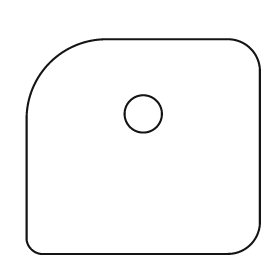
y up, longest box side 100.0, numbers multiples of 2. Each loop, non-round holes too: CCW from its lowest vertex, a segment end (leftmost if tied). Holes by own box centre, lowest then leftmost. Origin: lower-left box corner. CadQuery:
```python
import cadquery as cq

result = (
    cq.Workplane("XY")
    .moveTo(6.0, 0.0)
    .lineTo(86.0, 0.0)
    .threePointArc((96.0, 4.0), (100.0, 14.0))
    .lineTo(100.0, 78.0)
    .threePointArc((96.0, 88.0), (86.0, 92.0))
    .lineTo(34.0, 92.0)
    .threePointArc((10.0, 82.0), (0.0, 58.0))
    .lineTo(0.0, 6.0)
    .threePointArc((2.0, 2.0), (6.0, 0.0))
    .close()
    .moveTo(50.0, 60.0)
    .circle(8.0)
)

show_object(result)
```